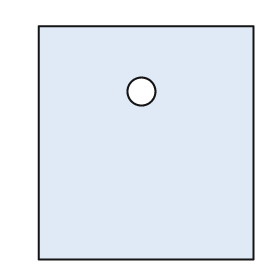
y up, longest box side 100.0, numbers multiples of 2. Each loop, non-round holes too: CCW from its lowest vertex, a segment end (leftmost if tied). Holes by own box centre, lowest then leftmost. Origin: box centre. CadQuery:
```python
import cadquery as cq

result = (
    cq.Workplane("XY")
    .moveTo(-46.0, -50.0)
    .lineTo(46.0, -50.0)
    .lineTo(46.0, 50.0)
    .lineTo(-46.0, 50.0)
    .close()
    .moveTo(-2.0, 22.0)
    .circle(6.0)
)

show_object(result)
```